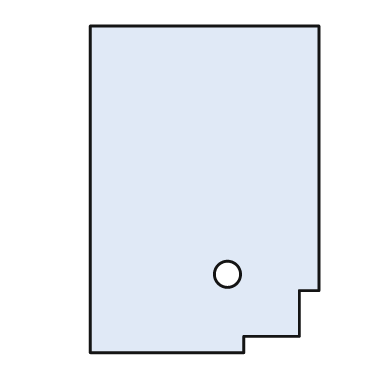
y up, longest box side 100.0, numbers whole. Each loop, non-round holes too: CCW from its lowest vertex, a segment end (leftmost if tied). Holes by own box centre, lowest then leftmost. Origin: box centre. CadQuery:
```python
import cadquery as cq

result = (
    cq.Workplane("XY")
    .moveTo(-35.0, -50.0)
    .lineTo(12.0, -50.0)
    .lineTo(12.0, -45.0)
    .lineTo(29.0, -45.0)
    .lineTo(29.0, -31.0)
    .lineTo(35.0, -31.0)
    .lineTo(35.0, 50.0)
    .lineTo(-35.0, 50.0)
    .close()
    .moveTo(7.0, -26.0)
    .circle(4.0)
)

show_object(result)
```